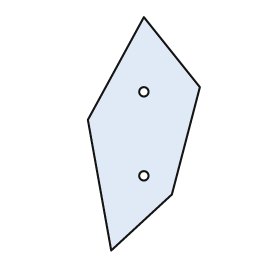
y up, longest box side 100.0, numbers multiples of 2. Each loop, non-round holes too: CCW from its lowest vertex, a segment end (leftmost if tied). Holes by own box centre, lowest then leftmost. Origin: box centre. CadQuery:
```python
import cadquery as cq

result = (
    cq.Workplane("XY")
    .moveTo(-14.0, -50.0)
    .lineTo(12.0, -26.0)
    .lineTo(24.0, 20.0)
    .lineTo(0.0, 50.0)
    .lineTo(-24.0, 6.0)
    .close()
    .moveTo(0.0, -18.0)
    .circle(2.0)
    .moveTo(0.0, 18.0)
    .circle(2.0)
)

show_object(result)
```